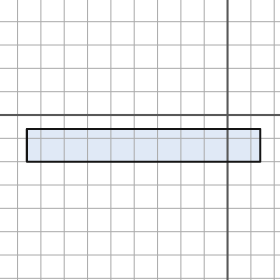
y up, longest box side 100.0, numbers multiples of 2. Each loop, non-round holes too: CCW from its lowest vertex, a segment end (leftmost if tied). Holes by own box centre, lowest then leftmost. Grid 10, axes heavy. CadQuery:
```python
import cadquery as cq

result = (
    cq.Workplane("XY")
    .moveTo(-86.0, -20.0)
    .lineTo(14.0, -20.0)
    .lineTo(14.0, -6.0)
    .lineTo(-86.0, -6.0)
    .close()
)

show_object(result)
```